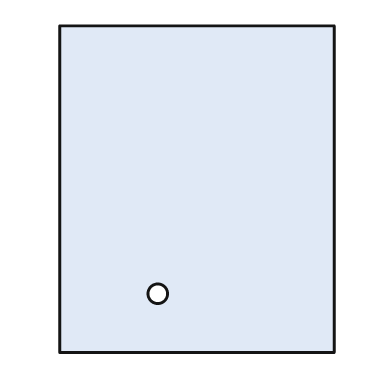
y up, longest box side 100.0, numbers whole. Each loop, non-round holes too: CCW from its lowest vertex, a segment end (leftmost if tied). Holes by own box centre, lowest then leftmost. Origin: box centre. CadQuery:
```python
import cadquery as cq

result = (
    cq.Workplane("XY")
    .moveTo(-42.0, -50.0)
    .lineTo(42.0, -50.0)
    .lineTo(42.0, 50.0)
    .lineTo(-42.0, 50.0)
    .close()
    .moveTo(-12.0, -32.0)
    .circle(3.0)
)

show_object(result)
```